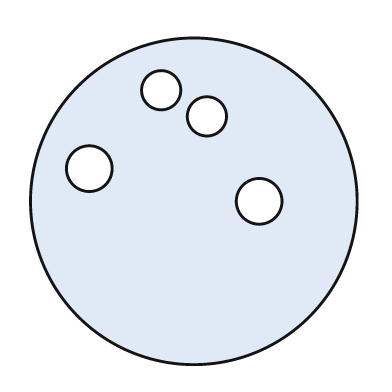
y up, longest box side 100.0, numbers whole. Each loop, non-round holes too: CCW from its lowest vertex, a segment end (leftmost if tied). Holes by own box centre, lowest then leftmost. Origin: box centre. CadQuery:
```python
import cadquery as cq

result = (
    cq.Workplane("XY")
    .moveTo(0.0, 0.0)
    .circle(50.0)
    .moveTo(20.0, 0.0)
    .circle(7.0)
    .moveTo(-32.0, 10.0)
    .circle(7.0)
    .moveTo(4.0, 26.0)
    .circle(6.0)
    .moveTo(-10.0, 34.0)
    .circle(6.0)
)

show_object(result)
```